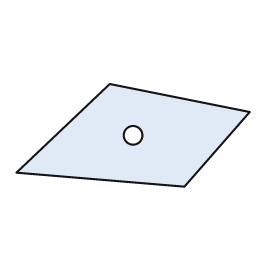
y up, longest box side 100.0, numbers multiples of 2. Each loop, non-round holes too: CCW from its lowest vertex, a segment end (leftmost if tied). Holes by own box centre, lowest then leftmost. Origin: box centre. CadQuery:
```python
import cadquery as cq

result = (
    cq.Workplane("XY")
    .moveTo(22.0, -22.0)
    .lineTo(50.0, 10.0)
    .lineTo(-10.0, 22.0)
    .lineTo(-50.0, -16.0)
    .close()
    .moveTo(0.0, 0.0)
    .circle(4.0)
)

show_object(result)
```